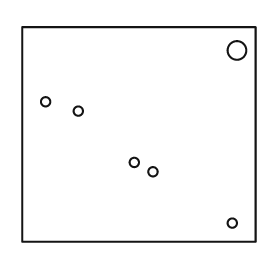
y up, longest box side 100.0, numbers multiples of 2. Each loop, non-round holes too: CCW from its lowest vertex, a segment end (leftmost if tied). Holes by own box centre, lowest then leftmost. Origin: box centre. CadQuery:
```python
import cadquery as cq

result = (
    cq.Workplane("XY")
    .moveTo(-50.0, -46.0)
    .lineTo(50.0, -46.0)
    .lineTo(50.0, 46.0)
    .lineTo(-50.0, 46.0)
    .close()
    .moveTo(40.0, -38.0)
    .circle(2.0)
    .moveTo(6.0, -16.0)
    .circle(2.0)
    .moveTo(-2.0, -12.0)
    .circle(2.0)
    .moveTo(-26.0, 10.0)
    .circle(2.0)
    .moveTo(-40.0, 14.0)
    .circle(2.0)
    .moveTo(42.0, 36.0)
    .circle(4.0)
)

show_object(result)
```